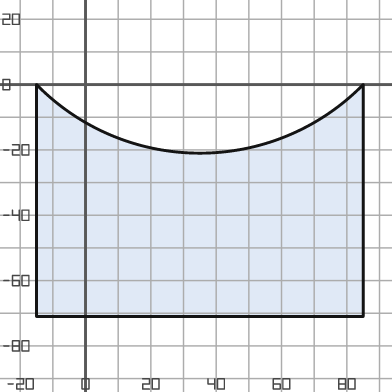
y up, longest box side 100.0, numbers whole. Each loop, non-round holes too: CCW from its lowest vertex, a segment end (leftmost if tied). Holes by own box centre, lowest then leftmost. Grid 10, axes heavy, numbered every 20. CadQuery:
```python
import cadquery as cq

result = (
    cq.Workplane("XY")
    .moveTo(-15.0, -71.0)
    .lineTo(85.0, -71.0)
    .lineTo(85.0, 0.0)
    .threePointArc((35.0, -21.0), (-15.0, 0.0))
    .close()
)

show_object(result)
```